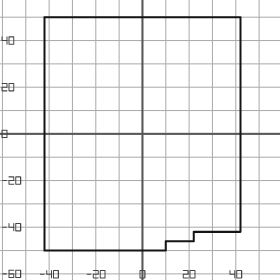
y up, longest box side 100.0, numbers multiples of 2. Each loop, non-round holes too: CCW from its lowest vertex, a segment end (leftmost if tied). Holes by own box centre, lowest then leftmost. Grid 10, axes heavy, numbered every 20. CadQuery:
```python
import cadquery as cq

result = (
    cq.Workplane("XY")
    .moveTo(-42.0, -50.0)
    .lineTo(10.0, -50.0)
    .lineTo(10.0, -46.0)
    .lineTo(22.0, -46.0)
    .lineTo(22.0, -42.0)
    .lineTo(42.0, -42.0)
    .lineTo(42.0, 50.0)
    .lineTo(-42.0, 50.0)
    .close()
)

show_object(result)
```